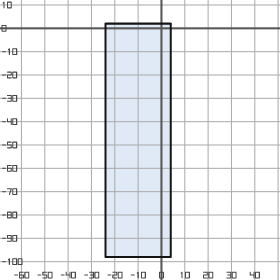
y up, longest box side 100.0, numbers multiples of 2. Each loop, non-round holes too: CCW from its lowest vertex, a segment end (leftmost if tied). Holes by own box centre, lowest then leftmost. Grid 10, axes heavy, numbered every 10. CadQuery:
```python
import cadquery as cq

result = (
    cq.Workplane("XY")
    .moveTo(-24.0, -98.0)
    .lineTo(4.0, -98.0)
    .lineTo(4.0, 2.0)
    .lineTo(-24.0, 2.0)
    .close()
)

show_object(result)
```